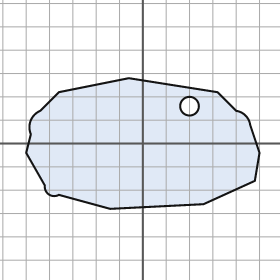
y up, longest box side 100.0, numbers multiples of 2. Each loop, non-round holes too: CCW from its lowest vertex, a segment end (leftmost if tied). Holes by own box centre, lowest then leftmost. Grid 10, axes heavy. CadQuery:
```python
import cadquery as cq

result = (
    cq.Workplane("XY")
    .moveTo(-14.0, -28.0)
    .lineTo(26.0, -26.0)
    .lineTo(48.0, -16.0)
    .lineTo(50.0, -4.0)
    .lineTo(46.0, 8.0)
    .threePointArc((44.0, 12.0), (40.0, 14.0))
    .lineTo(32.0, 22.0)
    .lineTo(-6.0, 28.0)
    .lineTo(-36.0, 22.0)
    .lineTo(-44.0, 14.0)
    .threePointArc((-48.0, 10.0), (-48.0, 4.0))
    .lineTo(-50.0, -4.0)
    .lineTo(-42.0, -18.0)
    .threePointArc((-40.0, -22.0), (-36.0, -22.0))
    .close()
    .moveTo(20.0, 16.0)
    .circle(4.0)
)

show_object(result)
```